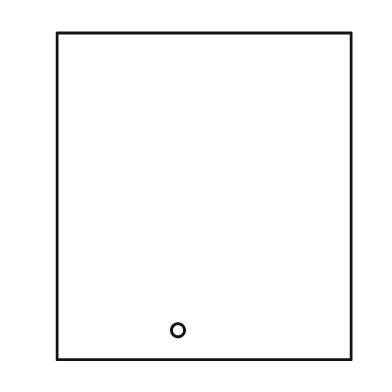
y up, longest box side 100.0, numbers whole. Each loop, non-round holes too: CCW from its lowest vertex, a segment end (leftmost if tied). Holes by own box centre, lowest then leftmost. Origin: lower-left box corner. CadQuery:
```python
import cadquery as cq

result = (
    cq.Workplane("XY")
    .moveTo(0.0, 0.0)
    .lineTo(90.0, 0.0)
    .lineTo(90.0, 100.0)
    .lineTo(0.0, 100.0)
    .close()
    .moveTo(37.0, 9.0)
    .circle(2.0)
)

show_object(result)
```